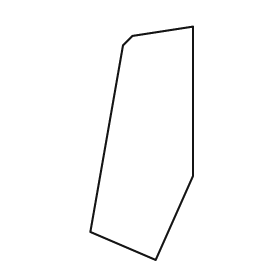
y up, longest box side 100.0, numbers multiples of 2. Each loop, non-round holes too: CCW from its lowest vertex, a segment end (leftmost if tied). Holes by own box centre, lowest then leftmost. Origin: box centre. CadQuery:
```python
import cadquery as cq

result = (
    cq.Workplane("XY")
    .moveTo(6.0, -50.0)
    .lineTo(22.0, -14.0)
    .lineTo(22.0, 50.0)
    .lineTo(-4.0, 46.0)
    .lineTo(-8.0, 42.0)
    .lineTo(-22.0, -38.0)
    .close()
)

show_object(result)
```